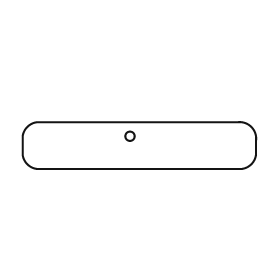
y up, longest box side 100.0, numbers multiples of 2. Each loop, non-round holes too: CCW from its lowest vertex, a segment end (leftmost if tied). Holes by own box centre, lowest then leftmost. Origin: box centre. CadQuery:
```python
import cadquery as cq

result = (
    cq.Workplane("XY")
    .moveTo(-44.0, -10.0)
    .lineTo(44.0, -10.0)
    .threePointArc((48.0, -8.0), (50.0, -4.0))
    .lineTo(50.0, 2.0)
    .threePointArc((48.0, 8.0), (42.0, 10.0))
    .lineTo(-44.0, 10.0)
    .threePointArc((-48.0, 8.0), (-50.0, 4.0))
    .lineTo(-50.0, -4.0)
    .threePointArc((-48.0, -8.0), (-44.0, -10.0))
    .close()
    .moveTo(-4.0, 4.0)
    .circle(2.0)
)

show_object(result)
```